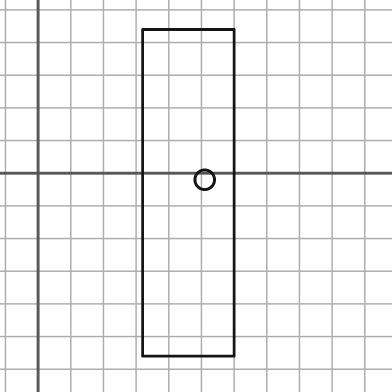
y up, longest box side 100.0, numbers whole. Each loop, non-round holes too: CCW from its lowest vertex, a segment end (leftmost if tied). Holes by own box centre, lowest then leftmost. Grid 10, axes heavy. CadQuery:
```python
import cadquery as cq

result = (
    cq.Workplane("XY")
    .moveTo(32.0, -56.0)
    .lineTo(60.0, -56.0)
    .lineTo(60.0, 44.0)
    .lineTo(32.0, 44.0)
    .close()
    .moveTo(51.0, -2.0)
    .circle(3.0)
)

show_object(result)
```